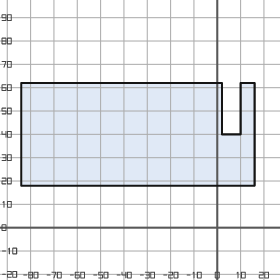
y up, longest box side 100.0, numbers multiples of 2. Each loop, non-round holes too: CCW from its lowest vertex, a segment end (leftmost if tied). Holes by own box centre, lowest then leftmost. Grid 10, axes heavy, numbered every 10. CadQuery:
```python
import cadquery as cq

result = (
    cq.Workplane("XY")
    .moveTo(-84.0, 18.0)
    .lineTo(16.0, 18.0)
    .lineTo(16.0, 62.0)
    .lineTo(10.0, 62.0)
    .lineTo(10.0, 40.0)
    .lineTo(2.0, 40.0)
    .lineTo(2.0, 62.0)
    .lineTo(-84.0, 62.0)
    .close()
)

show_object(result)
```